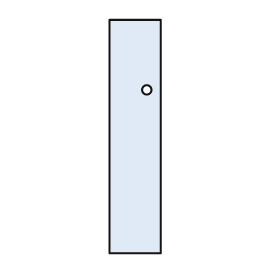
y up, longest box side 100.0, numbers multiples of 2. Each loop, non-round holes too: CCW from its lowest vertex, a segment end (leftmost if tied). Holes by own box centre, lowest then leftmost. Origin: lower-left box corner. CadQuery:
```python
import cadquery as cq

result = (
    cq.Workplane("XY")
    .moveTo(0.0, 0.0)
    .lineTo(22.0, 0.0)
    .lineTo(22.0, 100.0)
    .lineTo(0.0, 100.0)
    .close()
    .moveTo(16.0, 70.0)
    .circle(2.0)
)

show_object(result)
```